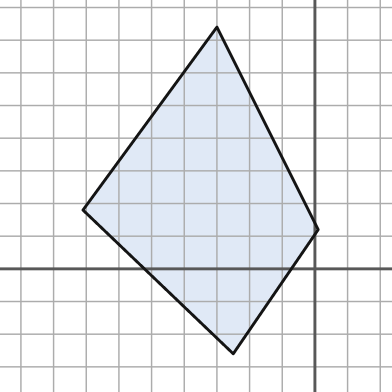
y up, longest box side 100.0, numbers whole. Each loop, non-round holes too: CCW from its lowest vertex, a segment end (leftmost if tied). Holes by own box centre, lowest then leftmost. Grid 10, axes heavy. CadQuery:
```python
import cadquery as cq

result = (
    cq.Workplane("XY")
    .moveTo(-25.0, -26.0)
    .lineTo(1.0, 12.0)
    .lineTo(-30.0, 74.0)
    .lineTo(-71.0, 18.0)
    .close()
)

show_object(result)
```